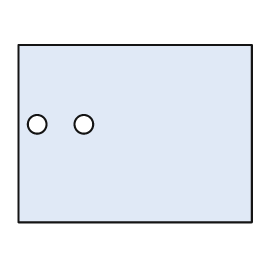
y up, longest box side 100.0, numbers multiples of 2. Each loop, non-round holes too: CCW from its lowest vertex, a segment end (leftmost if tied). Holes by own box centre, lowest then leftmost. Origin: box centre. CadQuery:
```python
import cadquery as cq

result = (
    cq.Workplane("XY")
    .moveTo(-50.0, -38.0)
    .lineTo(50.0, -38.0)
    .lineTo(50.0, 38.0)
    .lineTo(-50.0, 38.0)
    .close()
    .moveTo(-42.0, 4.0)
    .circle(4.0)
    .moveTo(-22.0, 4.0)
    .circle(4.0)
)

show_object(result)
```